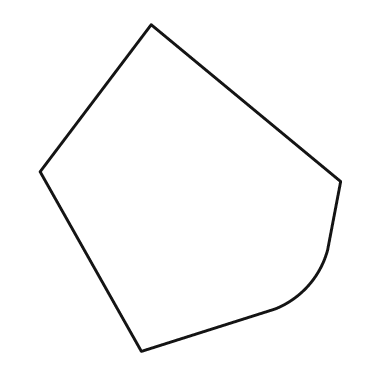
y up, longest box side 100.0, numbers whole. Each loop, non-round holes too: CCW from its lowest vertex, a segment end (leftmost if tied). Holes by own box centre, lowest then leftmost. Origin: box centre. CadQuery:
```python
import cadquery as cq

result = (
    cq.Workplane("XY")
    .moveTo(-15.0, -50.0)
    .lineTo(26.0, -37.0)
    .threePointArc((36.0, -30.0), (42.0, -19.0))
    .lineTo(46.0, 2.0)
    .lineTo(-12.0, 50.0)
    .lineTo(-46.0, 5.0)
    .close()
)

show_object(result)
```